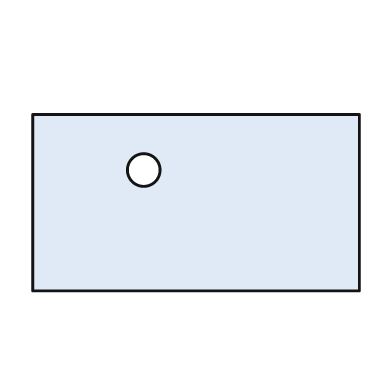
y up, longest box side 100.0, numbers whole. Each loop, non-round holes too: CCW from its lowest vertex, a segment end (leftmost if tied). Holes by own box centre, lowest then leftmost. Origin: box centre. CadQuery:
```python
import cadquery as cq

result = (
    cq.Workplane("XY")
    .moveTo(-50.0, -27.0)
    .lineTo(50.0, -27.0)
    .lineTo(50.0, 27.0)
    .lineTo(-50.0, 27.0)
    .close()
    .moveTo(-16.0, 10.0)
    .circle(5.0)
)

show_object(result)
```